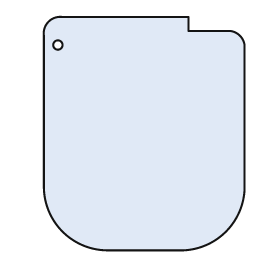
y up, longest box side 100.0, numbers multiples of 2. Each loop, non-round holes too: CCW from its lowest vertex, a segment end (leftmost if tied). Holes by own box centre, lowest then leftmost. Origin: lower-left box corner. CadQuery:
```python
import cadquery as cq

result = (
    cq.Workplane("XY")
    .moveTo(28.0, 0.0)
    .lineTo(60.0, 0.0)
    .threePointArc((78.0, 8.0), (86.0, 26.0))
    .lineTo(86.0, 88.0)
    .threePointArc((84.0, 92.0), (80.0, 94.0))
    .lineTo(62.0, 94.0)
    .lineTo(62.0, 100.0)
    .lineTo(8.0, 100.0)
    .threePointArc((2.0, 98.0), (0.0, 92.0))
    .lineTo(0.0, 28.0)
    .threePointArc((8.0, 8.0), (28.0, 0.0))
    .close()
    .moveTo(6.0, 88.0)
    .circle(2.0)
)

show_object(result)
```